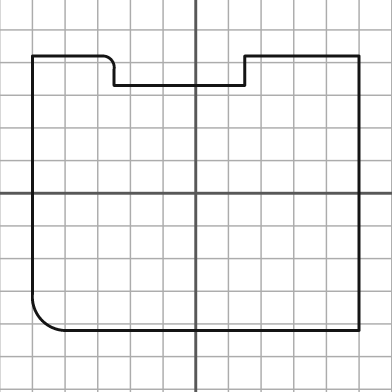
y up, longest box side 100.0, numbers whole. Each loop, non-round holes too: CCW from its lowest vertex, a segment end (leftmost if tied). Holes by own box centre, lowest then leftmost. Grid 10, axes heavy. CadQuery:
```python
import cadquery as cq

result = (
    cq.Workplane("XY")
    .moveTo(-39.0, -42.0)
    .lineTo(50.0, -42.0)
    .lineTo(50.0, 42.0)
    .lineTo(15.0, 42.0)
    .lineTo(15.0, 33.0)
    .lineTo(-25.0, 33.0)
    .lineTo(-25.0, 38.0)
    .threePointArc((-26.0, 41.0), (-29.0, 42.0))
    .lineTo(-50.0, 42.0)
    .lineTo(-50.0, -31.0)
    .threePointArc((-47.0, -39.0), (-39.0, -42.0))
    .close()
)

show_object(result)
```